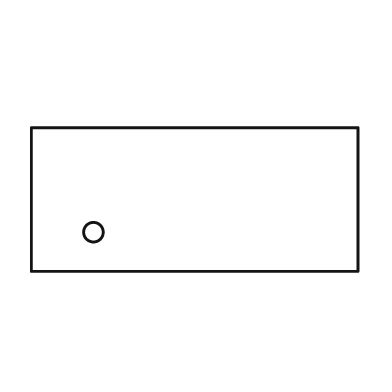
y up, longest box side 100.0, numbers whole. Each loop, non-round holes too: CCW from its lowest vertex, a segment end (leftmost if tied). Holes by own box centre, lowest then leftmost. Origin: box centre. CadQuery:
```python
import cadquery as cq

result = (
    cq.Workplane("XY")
    .moveTo(-50.0, -22.0)
    .lineTo(50.0, -22.0)
    .lineTo(50.0, 22.0)
    .lineTo(-50.0, 22.0)
    .close()
    .moveTo(-31.0, -10.0)
    .circle(3.0)
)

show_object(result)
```